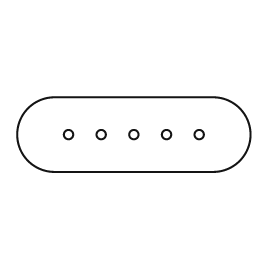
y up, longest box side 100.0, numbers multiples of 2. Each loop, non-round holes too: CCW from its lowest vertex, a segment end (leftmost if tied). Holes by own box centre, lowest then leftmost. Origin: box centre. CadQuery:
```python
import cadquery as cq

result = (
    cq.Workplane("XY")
    .moveTo(-34.0, -16.0)
    .lineTo(34.0, -16.0)
    .threePointArc((50.0, 0.0), (34.0, 16.0))
    .lineTo(-34.0, 16.0)
    .threePointArc((-50.0, 0.0), (-34.0, -16.0))
    .close()
    .moveTo(-28.0, 0.0)
    .circle(2.0)
    .moveTo(-14.0, 0.0)
    .circle(2.0)
    .moveTo(0.0, 0.0)
    .circle(2.0)
    .moveTo(14.0, 0.0)
    .circle(2.0)
    .moveTo(28.0, 0.0)
    .circle(2.0)
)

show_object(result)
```